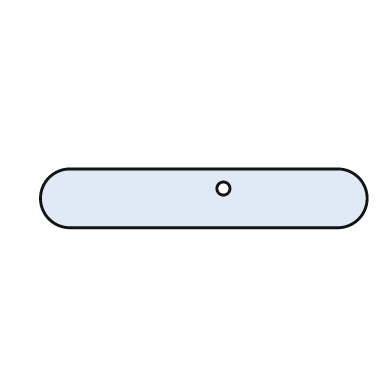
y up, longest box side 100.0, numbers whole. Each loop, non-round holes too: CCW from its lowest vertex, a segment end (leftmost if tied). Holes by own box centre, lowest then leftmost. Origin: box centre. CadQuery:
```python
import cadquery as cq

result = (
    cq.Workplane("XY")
    .moveTo(-41.0, -9.0)
    .lineTo(41.0, -9.0)
    .threePointArc((50.0, 0.0), (41.0, 9.0))
    .lineTo(-41.0, 9.0)
    .threePointArc((-50.0, 0.0), (-41.0, -9.0))
    .close()
    .moveTo(6.0, 3.0)
    .circle(2.0)
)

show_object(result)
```